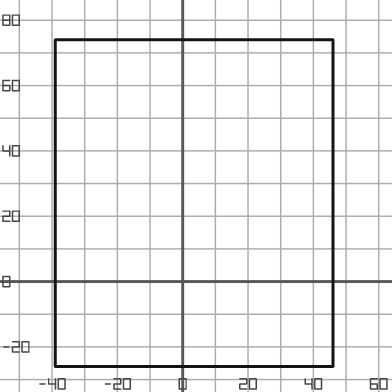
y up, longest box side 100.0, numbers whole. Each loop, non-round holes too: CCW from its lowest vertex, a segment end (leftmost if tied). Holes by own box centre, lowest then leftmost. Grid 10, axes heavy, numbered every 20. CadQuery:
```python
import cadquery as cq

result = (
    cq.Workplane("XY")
    .moveTo(-39.0, -26.0)
    .lineTo(46.0, -26.0)
    .lineTo(46.0, 74.0)
    .lineTo(-39.0, 74.0)
    .close()
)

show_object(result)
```